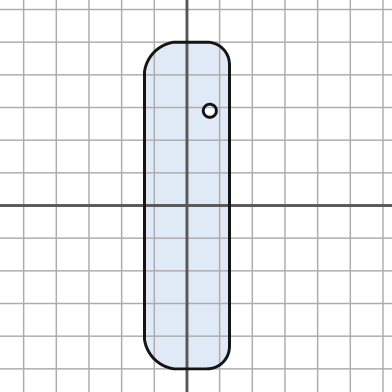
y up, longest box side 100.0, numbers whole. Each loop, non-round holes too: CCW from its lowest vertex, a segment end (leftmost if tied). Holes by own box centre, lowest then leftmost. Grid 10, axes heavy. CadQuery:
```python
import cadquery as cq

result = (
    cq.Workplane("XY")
    .moveTo(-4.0, -50.0)
    .lineTo(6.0, -50.0)
    .threePointArc((11.0, -48.0), (13.0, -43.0))
    .lineTo(13.0, 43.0)
    .threePointArc((11.0, 48.0), (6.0, 50.0))
    .lineTo(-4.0, 50.0)
    .threePointArc((-10.0, 47.0), (-13.0, 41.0))
    .lineTo(-13.0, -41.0)
    .threePointArc((-10.0, -47.0), (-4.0, -50.0))
    .close()
    .moveTo(7.0, 29.0)
    .circle(2.0)
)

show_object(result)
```